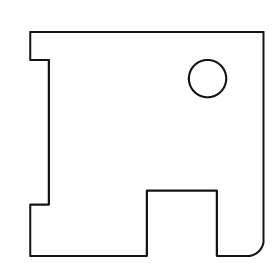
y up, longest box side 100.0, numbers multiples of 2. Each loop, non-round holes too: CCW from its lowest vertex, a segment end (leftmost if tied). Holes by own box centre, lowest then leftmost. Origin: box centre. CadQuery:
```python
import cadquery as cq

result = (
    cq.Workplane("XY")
    .moveTo(-50.0, -48.0)
    .lineTo(0.0, -48.0)
    .lineTo(0.0, -20.0)
    .lineTo(30.0, -20.0)
    .lineTo(30.0, -48.0)
    .lineTo(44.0, -48.0)
    .threePointArc((48.0, -46.0), (50.0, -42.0))
    .lineTo(50.0, 48.0)
    .lineTo(-50.0, 48.0)
    .lineTo(-50.0, 36.0)
    .lineTo(-42.0, 36.0)
    .lineTo(-42.0, -26.0)
    .lineTo(-50.0, -26.0)
    .close()
    .moveTo(26.0, 28.0)
    .circle(8.0)
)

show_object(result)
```